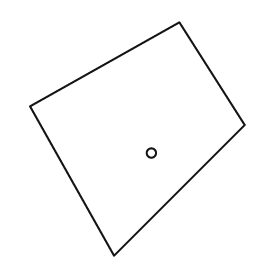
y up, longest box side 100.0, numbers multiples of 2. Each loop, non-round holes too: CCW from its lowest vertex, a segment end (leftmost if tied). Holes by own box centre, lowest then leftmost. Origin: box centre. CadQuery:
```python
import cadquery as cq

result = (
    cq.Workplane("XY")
    .moveTo(-10.0, -50.0)
    .lineTo(46.0, 6.0)
    .lineTo(18.0, 50.0)
    .lineTo(-46.0, 14.0)
    .close()
    .moveTo(6.0, -6.0)
    .circle(2.0)
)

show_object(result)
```